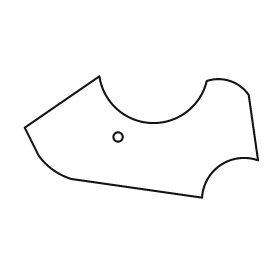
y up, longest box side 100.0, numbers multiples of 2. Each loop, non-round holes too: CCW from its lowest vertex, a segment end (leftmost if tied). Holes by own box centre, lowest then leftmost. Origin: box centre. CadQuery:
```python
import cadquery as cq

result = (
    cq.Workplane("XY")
    .moveTo(26.0, -26.0)
    .threePointArc((34.0, -12.0), (50.0, -10.0))
    .lineTo(46.0, 18.0)
    .threePointArc((38.0, 24.0), (28.0, 24.0))
    .threePointArc((4.0, 6.0), (-18.0, 26.0))
    .lineTo(-50.0, 4.0)
    .lineTo(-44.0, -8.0)
    .threePointArc((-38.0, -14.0), (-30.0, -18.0))
    .close()
    .moveTo(-10.0, 0.0)
    .circle(2.0)
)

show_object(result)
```